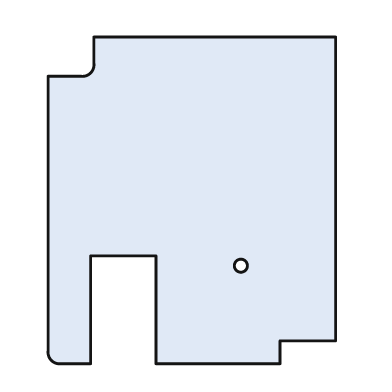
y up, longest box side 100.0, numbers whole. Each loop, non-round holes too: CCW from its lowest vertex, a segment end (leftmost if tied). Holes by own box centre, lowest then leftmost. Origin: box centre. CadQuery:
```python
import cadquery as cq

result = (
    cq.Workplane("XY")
    .moveTo(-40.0, -50.0)
    .lineTo(-31.0, -50.0)
    .lineTo(-31.0, -17.0)
    .lineTo(-11.0, -17.0)
    .lineTo(-11.0, -50.0)
    .lineTo(27.0, -50.0)
    .lineTo(27.0, -43.0)
    .lineTo(44.0, -43.0)
    .lineTo(44.0, 50.0)
    .lineTo(-30.0, 50.0)
    .lineTo(-30.0, 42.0)
    .threePointArc((-31.0, 39.0), (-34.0, 38.0))
    .lineTo(-44.0, 38.0)
    .lineTo(-44.0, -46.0)
    .threePointArc((-43.0, -49.0), (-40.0, -50.0))
    .close()
    .moveTo(15.0, -20.0)
    .circle(2.0)
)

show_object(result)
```